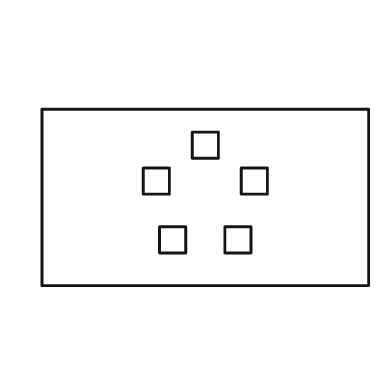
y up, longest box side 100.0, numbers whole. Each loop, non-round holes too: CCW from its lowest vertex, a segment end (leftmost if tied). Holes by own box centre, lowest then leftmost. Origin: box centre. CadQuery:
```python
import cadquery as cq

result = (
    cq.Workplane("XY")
    .moveTo(-50.0, -27.0)
    .lineTo(50.0, -27.0)
    .lineTo(50.0, 27.0)
    .lineTo(-50.0, 27.0)
    .close()
    .moveTo(-14.0, -17.0)
    .lineTo(-6.0, -17.0)
    .lineTo(-6.0, -9.0)
    .lineTo(-14.0, -9.0)
    .close()
    .moveTo(6.0, -17.0)
    .lineTo(14.0, -17.0)
    .lineTo(14.0, -9.0)
    .lineTo(6.0, -9.0)
    .close()
    .moveTo(-19.0, 1.0)
    .lineTo(-11.0, 1.0)
    .lineTo(-11.0, 9.0)
    .lineTo(-19.0, 9.0)
    .close()
    .moveTo(11.0, 1.0)
    .lineTo(19.0, 1.0)
    .lineTo(19.0, 9.0)
    .lineTo(11.0, 9.0)
    .close()
    .moveTo(-4.0, 12.0)
    .lineTo(4.0, 12.0)
    .lineTo(4.0, 20.0)
    .lineTo(-4.0, 20.0)
    .close()
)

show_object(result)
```